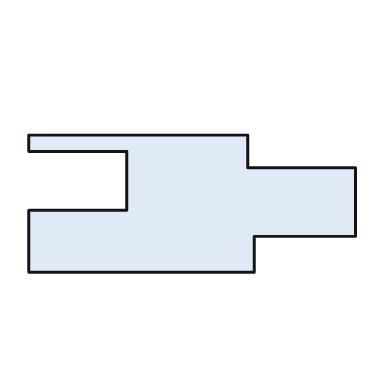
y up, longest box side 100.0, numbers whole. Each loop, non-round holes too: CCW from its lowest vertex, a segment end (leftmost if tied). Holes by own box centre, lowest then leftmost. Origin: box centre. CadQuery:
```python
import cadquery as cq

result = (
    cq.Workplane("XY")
    .moveTo(-50.0, -21.0)
    .lineTo(19.0, -21.0)
    .lineTo(19.0, -10.0)
    .lineTo(50.0, -10.0)
    .lineTo(50.0, 11.0)
    .lineTo(17.0, 11.0)
    .lineTo(17.0, 21.0)
    .lineTo(-50.0, 21.0)
    .lineTo(-50.0, 16.0)
    .lineTo(-20.0, 16.0)
    .lineTo(-20.0, -2.0)
    .lineTo(-50.0, -2.0)
    .close()
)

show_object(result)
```